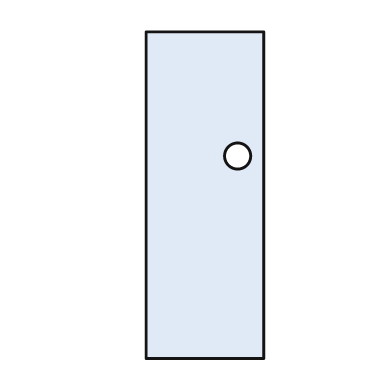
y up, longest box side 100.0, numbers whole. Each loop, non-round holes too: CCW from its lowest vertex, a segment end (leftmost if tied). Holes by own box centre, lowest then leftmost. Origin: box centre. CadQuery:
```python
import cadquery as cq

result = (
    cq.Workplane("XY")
    .moveTo(-18.0, -50.0)
    .lineTo(18.0, -50.0)
    .lineTo(18.0, 50.0)
    .lineTo(-18.0, 50.0)
    .close()
    .moveTo(10.0, 12.0)
    .circle(4.0)
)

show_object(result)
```